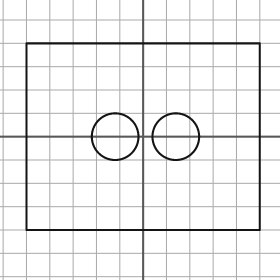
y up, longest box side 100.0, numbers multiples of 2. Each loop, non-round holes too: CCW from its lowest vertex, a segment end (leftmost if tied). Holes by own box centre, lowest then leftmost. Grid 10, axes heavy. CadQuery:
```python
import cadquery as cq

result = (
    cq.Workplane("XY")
    .moveTo(-50.0, -40.0)
    .lineTo(50.0, -40.0)
    .lineTo(50.0, 40.0)
    .lineTo(-50.0, 40.0)
    .close()
    .moveTo(-12.0, 0.0)
    .circle(10.0)
    .moveTo(14.0, 0.0)
    .circle(10.0)
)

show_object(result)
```